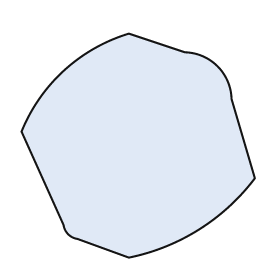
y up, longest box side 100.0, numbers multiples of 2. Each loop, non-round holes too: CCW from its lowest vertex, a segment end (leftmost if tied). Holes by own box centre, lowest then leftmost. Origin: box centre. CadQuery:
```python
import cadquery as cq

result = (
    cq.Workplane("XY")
    .moveTo(-4.0, -48.0)
    .threePointArc((26.0, -36.0), (50.0, -14.0))
    .lineTo(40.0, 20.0)
    .threePointArc((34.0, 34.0), (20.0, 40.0))
    .lineTo(-4.0, 48.0)
    .threePointArc((-32.0, 32.0), (-50.0, 6.0))
    .lineTo(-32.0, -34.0)
    .threePointArc((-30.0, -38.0), (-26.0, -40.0))
    .close()
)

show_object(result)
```